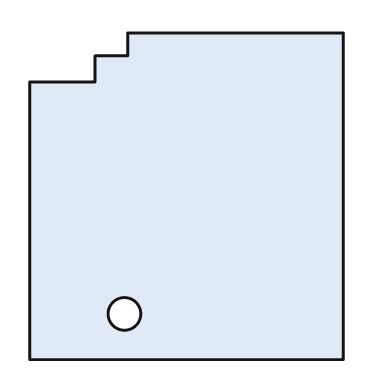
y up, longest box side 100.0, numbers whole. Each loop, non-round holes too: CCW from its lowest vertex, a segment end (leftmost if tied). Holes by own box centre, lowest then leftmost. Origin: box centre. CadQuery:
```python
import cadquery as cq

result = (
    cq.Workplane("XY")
    .moveTo(-48.0, -50.0)
    .lineTo(48.0, -50.0)
    .lineTo(48.0, 50.0)
    .lineTo(-18.0, 50.0)
    .lineTo(-18.0, 43.0)
    .lineTo(-28.0, 43.0)
    .lineTo(-28.0, 35.0)
    .lineTo(-48.0, 35.0)
    .close()
    .moveTo(-19.0, -36.0)
    .circle(5.0)
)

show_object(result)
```